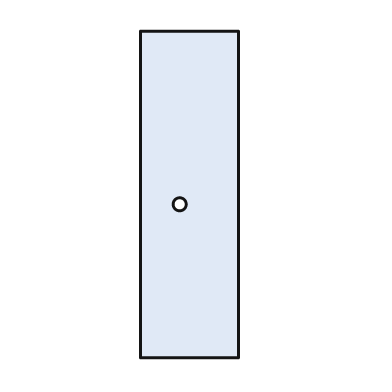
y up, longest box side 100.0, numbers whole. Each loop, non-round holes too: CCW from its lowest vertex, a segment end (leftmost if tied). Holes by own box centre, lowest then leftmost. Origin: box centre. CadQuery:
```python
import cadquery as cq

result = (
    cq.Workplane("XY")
    .moveTo(-15.0, -50.0)
    .lineTo(15.0, -50.0)
    .lineTo(15.0, 50.0)
    .lineTo(-15.0, 50.0)
    .close()
    .moveTo(-3.0, -3.0)
    .circle(2.0)
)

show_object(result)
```